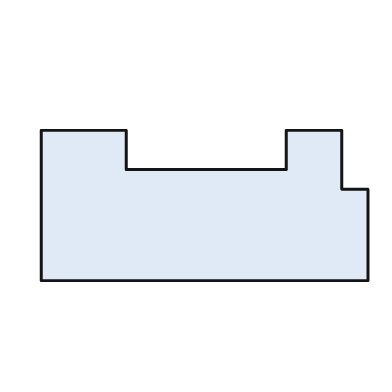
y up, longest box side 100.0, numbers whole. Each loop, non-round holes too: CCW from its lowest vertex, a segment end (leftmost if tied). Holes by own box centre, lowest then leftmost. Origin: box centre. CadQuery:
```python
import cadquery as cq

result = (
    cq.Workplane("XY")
    .moveTo(-50.0, -23.0)
    .lineTo(50.0, -23.0)
    .lineTo(50.0, 5.0)
    .lineTo(42.0, 5.0)
    .lineTo(42.0, 23.0)
    .lineTo(25.0, 23.0)
    .lineTo(25.0, 11.0)
    .lineTo(-24.0, 11.0)
    .lineTo(-24.0, 23.0)
    .lineTo(-50.0, 23.0)
    .close()
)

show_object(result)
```